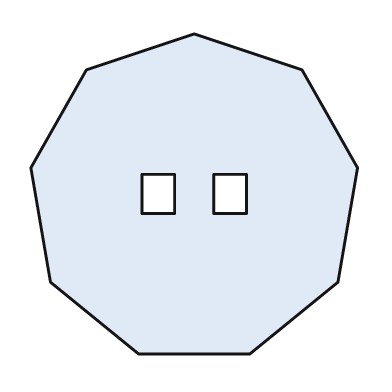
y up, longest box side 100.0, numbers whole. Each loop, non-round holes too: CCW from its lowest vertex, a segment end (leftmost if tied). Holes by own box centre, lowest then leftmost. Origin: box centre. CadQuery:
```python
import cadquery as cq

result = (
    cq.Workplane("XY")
    .moveTo(-17.0, -49.0)
    .lineTo(17.0, -49.0)
    .lineTo(44.0, -27.0)
    .lineTo(50.0, 8.0)
    .lineTo(33.0, 38.0)
    .lineTo(0.0, 49.0)
    .lineTo(-33.0, 38.0)
    .lineTo(-50.0, 8.0)
    .lineTo(-44.0, -27.0)
    .close()
    .moveTo(-16.0, -6.0)
    .lineTo(-6.0, -6.0)
    .lineTo(-6.0, 6.0)
    .lineTo(-16.0, 6.0)
    .close()
    .moveTo(6.0, -6.0)
    .lineTo(16.0, -6.0)
    .lineTo(16.0, 6.0)
    .lineTo(6.0, 6.0)
    .close()
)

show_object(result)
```